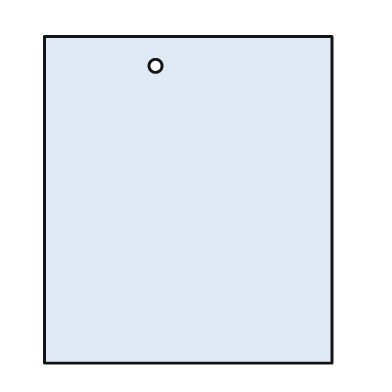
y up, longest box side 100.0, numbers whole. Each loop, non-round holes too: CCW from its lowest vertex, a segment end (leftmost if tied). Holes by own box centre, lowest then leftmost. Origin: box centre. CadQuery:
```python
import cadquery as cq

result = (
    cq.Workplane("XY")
    .moveTo(-44.0, -50.0)
    .lineTo(44.0, -50.0)
    .lineTo(44.0, 50.0)
    .lineTo(-44.0, 50.0)
    .close()
    .moveTo(-10.0, 41.0)
    .circle(2.0)
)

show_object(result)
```